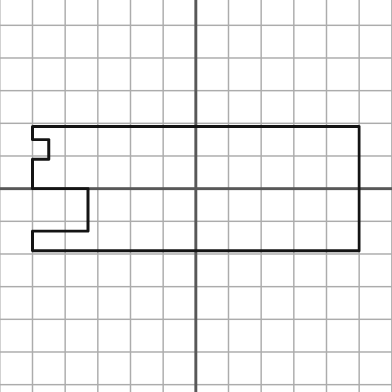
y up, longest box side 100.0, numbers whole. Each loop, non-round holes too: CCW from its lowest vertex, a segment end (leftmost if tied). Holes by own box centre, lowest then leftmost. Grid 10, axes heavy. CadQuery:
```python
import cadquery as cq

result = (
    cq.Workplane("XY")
    .moveTo(-50.0, -19.0)
    .lineTo(50.0, -19.0)
    .lineTo(50.0, 19.0)
    .lineTo(-50.0, 19.0)
    .lineTo(-50.0, 15.0)
    .lineTo(-45.0, 15.0)
    .lineTo(-45.0, 9.0)
    .lineTo(-50.0, 9.0)
    .lineTo(-50.0, 0.0)
    .lineTo(-33.0, 0.0)
    .lineTo(-33.0, -13.0)
    .lineTo(-50.0, -13.0)
    .close()
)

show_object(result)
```